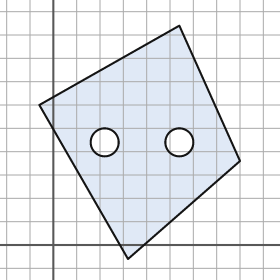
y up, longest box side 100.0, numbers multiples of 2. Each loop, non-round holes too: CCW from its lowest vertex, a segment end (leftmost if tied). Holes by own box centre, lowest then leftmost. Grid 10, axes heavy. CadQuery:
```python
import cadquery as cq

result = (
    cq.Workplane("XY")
    .moveTo(32.0, -6.0)
    .lineTo(80.0, 36.0)
    .lineTo(54.0, 94.0)
    .lineTo(-6.0, 60.0)
    .close()
    .moveTo(22.0, 44.0)
    .circle(6.0)
    .moveTo(54.0, 44.0)
    .circle(6.0)
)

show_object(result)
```